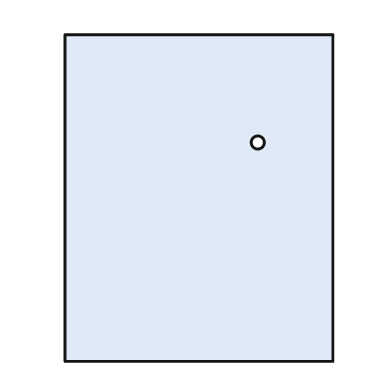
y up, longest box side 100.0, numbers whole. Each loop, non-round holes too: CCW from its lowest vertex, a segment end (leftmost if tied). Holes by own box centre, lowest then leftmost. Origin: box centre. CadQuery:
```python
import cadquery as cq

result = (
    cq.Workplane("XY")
    .moveTo(-41.0, -50.0)
    .lineTo(41.0, -50.0)
    .lineTo(41.0, 50.0)
    .lineTo(-41.0, 50.0)
    .close()
    .moveTo(18.0, 17.0)
    .circle(2.0)
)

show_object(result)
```